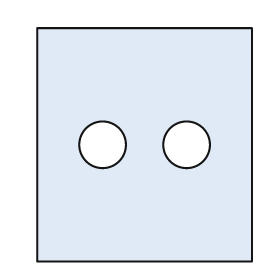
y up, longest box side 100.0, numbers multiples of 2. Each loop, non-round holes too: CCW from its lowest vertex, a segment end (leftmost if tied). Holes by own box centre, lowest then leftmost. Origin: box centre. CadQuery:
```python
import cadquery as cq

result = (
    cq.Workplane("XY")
    .moveTo(-46.0, -50.0)
    .lineTo(46.0, -50.0)
    .lineTo(46.0, 50.0)
    .lineTo(-46.0, 50.0)
    .close()
    .moveTo(-18.0, 0.0)
    .circle(10.0)
    .moveTo(18.0, 0.0)
    .circle(10.0)
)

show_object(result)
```